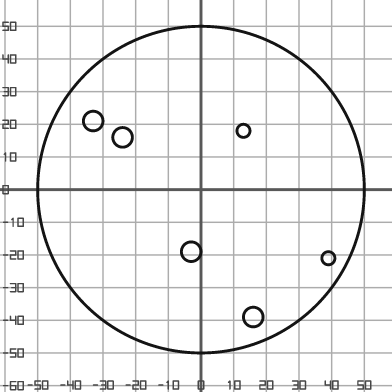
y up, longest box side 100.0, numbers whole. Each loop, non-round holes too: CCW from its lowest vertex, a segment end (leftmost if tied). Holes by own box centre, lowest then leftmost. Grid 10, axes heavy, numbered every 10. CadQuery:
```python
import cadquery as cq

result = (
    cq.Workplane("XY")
    .moveTo(0.0, 0.0)
    .circle(50.0)
    .moveTo(16.0, -39.0)
    .circle(3.0)
    .moveTo(39.0, -21.0)
    .circle(2.0)
    .moveTo(-3.0, -19.0)
    .circle(3.0)
    .moveTo(-24.0, 16.0)
    .circle(3.0)
    .moveTo(13.0, 18.0)
    .circle(2.0)
    .moveTo(-33.0, 21.0)
    .circle(3.0)
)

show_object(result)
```